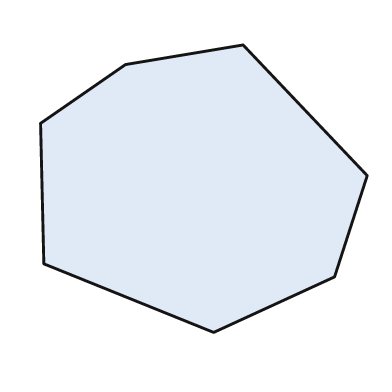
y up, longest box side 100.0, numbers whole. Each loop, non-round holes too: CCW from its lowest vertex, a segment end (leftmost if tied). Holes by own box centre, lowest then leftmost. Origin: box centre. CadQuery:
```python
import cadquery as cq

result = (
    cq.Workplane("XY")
    .moveTo(3.0, -44.0)
    .lineTo(40.0, -27.0)
    .lineTo(50.0, 4.0)
    .lineTo(12.0, 44.0)
    .lineTo(-24.0, 38.0)
    .lineTo(-50.0, 20.0)
    .lineTo(-49.0, -23.0)
    .close()
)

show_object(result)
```